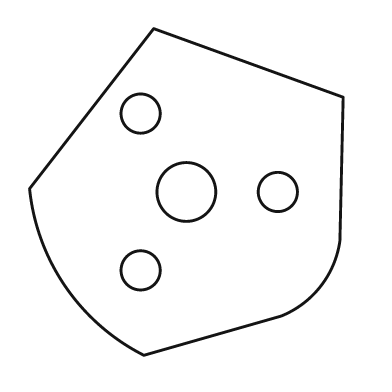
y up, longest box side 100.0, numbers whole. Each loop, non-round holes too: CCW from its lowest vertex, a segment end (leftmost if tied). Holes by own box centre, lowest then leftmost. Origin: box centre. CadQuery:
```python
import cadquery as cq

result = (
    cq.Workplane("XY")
    .moveTo(-13.0, -50.0)
    .lineTo(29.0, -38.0)
    .threePointArc((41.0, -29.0), (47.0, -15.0))
    .lineTo(48.0, 29.0)
    .lineTo(-10.0, 50.0)
    .lineTo(-48.0, 1.0)
    .threePointArc((-37.0, -29.0), (-13.0, -50.0))
    .close()
    .moveTo(-14.0, -24.0)
    .circle(6.0)
    .moveTo(0.0, 0.0)
    .circle(9.0)
    .moveTo(28.0, 0.0)
    .circle(6.0)
    .moveTo(-14.0, 24.0)
    .circle(6.0)
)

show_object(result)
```